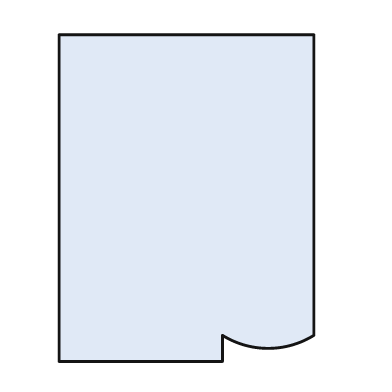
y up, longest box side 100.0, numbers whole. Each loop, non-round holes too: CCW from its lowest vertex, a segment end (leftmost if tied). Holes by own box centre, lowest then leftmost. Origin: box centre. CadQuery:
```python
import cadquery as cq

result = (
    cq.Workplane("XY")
    .moveTo(-39.0, -50.0)
    .lineTo(11.0, -50.0)
    .lineTo(11.0, -42.0)
    .threePointArc((25.0, -46.0), (39.0, -42.0))
    .lineTo(39.0, 50.0)
    .lineTo(-39.0, 50.0)
    .close()
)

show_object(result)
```